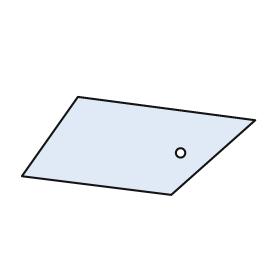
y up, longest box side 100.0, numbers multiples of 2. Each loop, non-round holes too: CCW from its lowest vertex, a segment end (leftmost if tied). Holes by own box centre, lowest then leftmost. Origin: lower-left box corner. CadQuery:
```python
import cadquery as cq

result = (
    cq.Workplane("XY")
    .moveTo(64.0, 0.0)
    .lineTo(100.0, 32.0)
    .lineTo(24.0, 42.0)
    .lineTo(0.0, 8.0)
    .close()
    .moveTo(68.0, 18.0)
    .circle(2.0)
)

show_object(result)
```